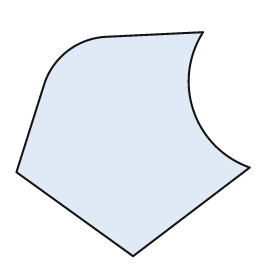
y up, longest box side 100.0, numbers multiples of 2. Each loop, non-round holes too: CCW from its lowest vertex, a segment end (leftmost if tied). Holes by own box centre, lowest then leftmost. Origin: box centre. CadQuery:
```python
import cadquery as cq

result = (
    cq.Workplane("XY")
    .moveTo(0.0, -48.0)
    .lineTo(50.0, -10.0)
    .threePointArc((26.0, 14.0), (30.0, 48.0))
    .lineTo(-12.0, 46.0)
    .threePointArc((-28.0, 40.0), (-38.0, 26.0))
    .lineTo(-50.0, -12.0)
    .close()
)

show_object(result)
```